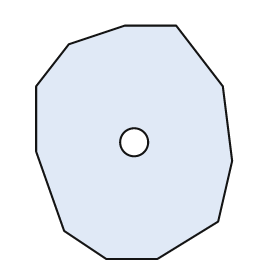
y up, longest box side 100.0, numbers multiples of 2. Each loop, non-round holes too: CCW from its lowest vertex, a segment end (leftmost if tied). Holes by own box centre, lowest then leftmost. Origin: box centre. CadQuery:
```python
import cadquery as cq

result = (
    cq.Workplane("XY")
    .moveTo(-12.0, -50.0)
    .lineTo(10.0, -50.0)
    .lineTo(36.0, -34.0)
    .lineTo(42.0, -8.0)
    .lineTo(38.0, 24.0)
    .lineTo(18.0, 50.0)
    .lineTo(-4.0, 50.0)
    .lineTo(-28.0, 42.0)
    .lineTo(-42.0, 24.0)
    .lineTo(-42.0, -4.0)
    .lineTo(-30.0, -38.0)
    .close()
    .moveTo(0.0, 0.0)
    .circle(6.0)
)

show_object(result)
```